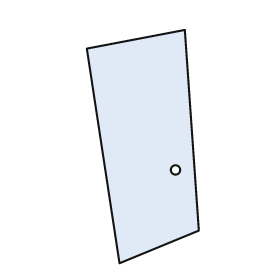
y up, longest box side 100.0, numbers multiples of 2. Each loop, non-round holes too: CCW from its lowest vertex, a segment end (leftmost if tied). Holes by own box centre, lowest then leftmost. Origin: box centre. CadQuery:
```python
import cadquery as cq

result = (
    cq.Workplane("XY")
    .moveTo(-10.0, -50.0)
    .lineTo(24.0, -36.0)
    .lineTo(18.0, 50.0)
    .lineTo(-24.0, 42.0)
    .close()
    .moveTo(14.0, -10.0)
    .circle(2.0)
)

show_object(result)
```